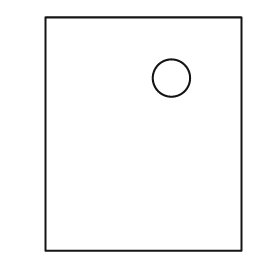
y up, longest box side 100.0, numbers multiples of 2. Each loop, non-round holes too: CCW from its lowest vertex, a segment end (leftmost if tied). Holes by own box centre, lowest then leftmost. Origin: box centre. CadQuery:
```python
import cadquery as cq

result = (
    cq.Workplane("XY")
    .moveTo(-42.0, -50.0)
    .lineTo(42.0, -50.0)
    .lineTo(42.0, 50.0)
    .lineTo(-42.0, 50.0)
    .close()
    .moveTo(12.0, 24.0)
    .circle(8.0)
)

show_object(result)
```